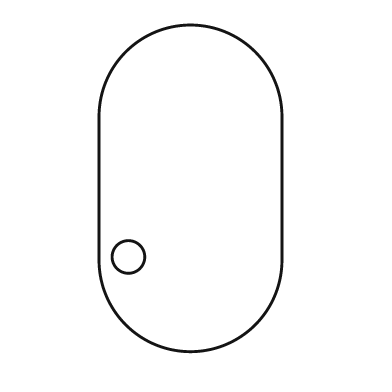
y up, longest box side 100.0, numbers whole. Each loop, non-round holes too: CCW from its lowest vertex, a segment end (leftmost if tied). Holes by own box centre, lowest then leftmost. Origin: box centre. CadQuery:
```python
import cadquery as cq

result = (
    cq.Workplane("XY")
    .moveTo(-28.0, -22.0)
    .threePointArc((0.0, -50.0), (28.0, -22.0))
    .lineTo(28.0, 22.0)
    .threePointArc((0.0, 50.0), (-28.0, 22.0))
    .close()
    .moveTo(-19.0, -21.0)
    .circle(5.0)
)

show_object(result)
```